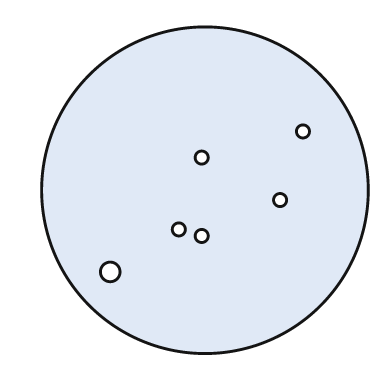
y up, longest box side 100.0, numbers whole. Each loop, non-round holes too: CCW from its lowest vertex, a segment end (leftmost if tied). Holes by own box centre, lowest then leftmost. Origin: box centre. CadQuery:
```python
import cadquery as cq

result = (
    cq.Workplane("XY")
    .moveTo(0.0, 0.0)
    .circle(50.0)
    .moveTo(-29.0, -25.0)
    .circle(3.0)
    .moveTo(-1.0, -14.0)
    .circle(2.0)
    .moveTo(-8.0, -12.0)
    .circle(2.0)
    .moveTo(23.0, -3.0)
    .circle(2.0)
    .moveTo(-1.0, 10.0)
    .circle(2.0)
    .moveTo(30.0, 18.0)
    .circle(2.0)
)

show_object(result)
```